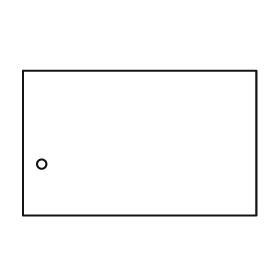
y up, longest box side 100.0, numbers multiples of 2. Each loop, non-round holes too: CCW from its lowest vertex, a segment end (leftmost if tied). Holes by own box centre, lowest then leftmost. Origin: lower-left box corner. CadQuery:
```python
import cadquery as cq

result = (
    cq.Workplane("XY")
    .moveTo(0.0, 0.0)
    .lineTo(100.0, 0.0)
    .lineTo(100.0, 62.0)
    .lineTo(0.0, 62.0)
    .close()
    .moveTo(8.0, 22.0)
    .circle(2.0)
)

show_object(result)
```